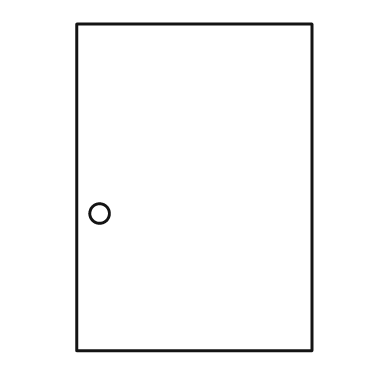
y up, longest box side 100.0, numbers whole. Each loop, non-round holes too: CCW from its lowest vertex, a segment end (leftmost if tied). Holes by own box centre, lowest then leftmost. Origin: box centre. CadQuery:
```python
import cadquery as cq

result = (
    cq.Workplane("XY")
    .moveTo(-36.0, -50.0)
    .lineTo(36.0, -50.0)
    .lineTo(36.0, 50.0)
    .lineTo(-36.0, 50.0)
    .close()
    .moveTo(-29.0, -8.0)
    .circle(3.0)
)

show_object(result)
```